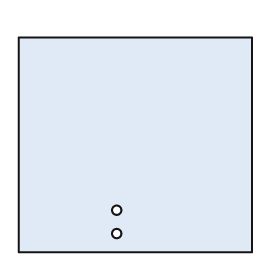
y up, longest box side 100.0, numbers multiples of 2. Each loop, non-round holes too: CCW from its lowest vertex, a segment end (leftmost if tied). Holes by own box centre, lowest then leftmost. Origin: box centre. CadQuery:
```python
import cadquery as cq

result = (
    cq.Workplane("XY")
    .moveTo(-50.0, -46.0)
    .lineTo(50.0, -46.0)
    .lineTo(50.0, 46.0)
    .lineTo(-50.0, 46.0)
    .close()
    .moveTo(-8.0, -38.0)
    .circle(2.0)
    .moveTo(-8.0, -28.0)
    .circle(2.0)
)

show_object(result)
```